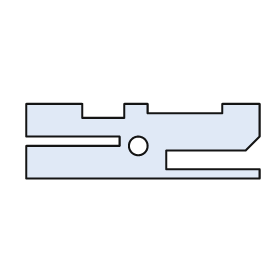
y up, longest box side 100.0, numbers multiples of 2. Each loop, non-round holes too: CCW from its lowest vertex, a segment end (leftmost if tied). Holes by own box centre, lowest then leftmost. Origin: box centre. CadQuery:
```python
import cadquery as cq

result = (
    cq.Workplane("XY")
    .moveTo(-50.0, -16.0)
    .lineTo(50.0, -16.0)
    .lineTo(50.0, -12.0)
    .lineTo(10.0, -12.0)
    .lineTo(10.0, -4.0)
    .lineTo(44.0, -4.0)
    .lineTo(50.0, 2.0)
    .lineTo(50.0, 16.0)
    .lineTo(34.0, 16.0)
    .lineTo(34.0, 12.0)
    .lineTo(2.0, 12.0)
    .lineTo(2.0, 16.0)
    .lineTo(-8.0, 16.0)
    .lineTo(-8.0, 10.0)
    .lineTo(-26.0, 10.0)
    .lineTo(-26.0, 16.0)
    .lineTo(-50.0, 16.0)
    .lineTo(-50.0, 2.0)
    .lineTo(-10.0, 2.0)
    .lineTo(-10.0, -2.0)
    .lineTo(-50.0, -2.0)
    .close()
    .moveTo(-2.0, -2.0)
    .circle(4.0)
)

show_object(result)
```